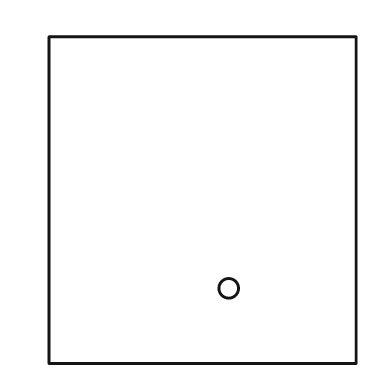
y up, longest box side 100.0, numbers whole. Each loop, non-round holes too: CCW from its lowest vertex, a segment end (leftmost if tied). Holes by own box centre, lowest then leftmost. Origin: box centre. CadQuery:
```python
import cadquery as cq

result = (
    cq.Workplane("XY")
    .moveTo(-47.0, -50.0)
    .lineTo(47.0, -50.0)
    .lineTo(47.0, 50.0)
    .lineTo(-47.0, 50.0)
    .close()
    .moveTo(8.0, -27.0)
    .circle(3.0)
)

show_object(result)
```